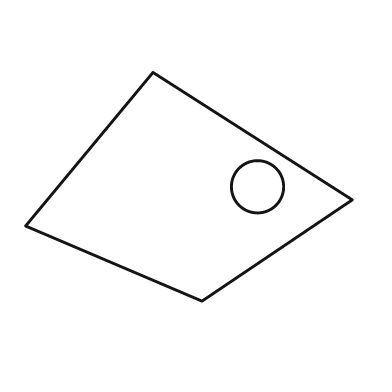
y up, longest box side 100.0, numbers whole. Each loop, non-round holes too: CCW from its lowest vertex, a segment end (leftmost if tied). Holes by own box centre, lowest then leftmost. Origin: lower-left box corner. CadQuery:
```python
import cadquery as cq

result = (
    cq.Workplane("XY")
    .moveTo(54.0, 0.0)
    .lineTo(100.0, 31.0)
    .lineTo(39.0, 70.0)
    .lineTo(0.0, 23.0)
    .close()
    .moveTo(71.0, 35.0)
    .circle(8.0)
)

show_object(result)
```